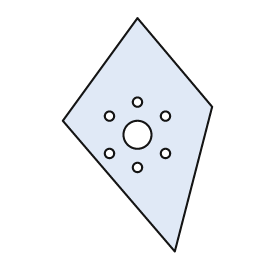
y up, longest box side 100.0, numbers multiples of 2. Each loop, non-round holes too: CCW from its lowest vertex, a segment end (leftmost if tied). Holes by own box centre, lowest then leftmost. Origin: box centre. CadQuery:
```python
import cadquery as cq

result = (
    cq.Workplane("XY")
    .moveTo(16.0, -50.0)
    .lineTo(32.0, 12.0)
    .lineTo(0.0, 50.0)
    .lineTo(-32.0, 6.0)
    .close()
    .moveTo(0.0, -14.0)
    .circle(2.0)
    .moveTo(-12.0, -8.0)
    .circle(2.0)
    .moveTo(12.0, -8.0)
    .circle(2.0)
    .moveTo(0.0, 0.0)
    .circle(6.0)
    .moveTo(-12.0, 8.0)
    .circle(2.0)
    .moveTo(12.0, 8.0)
    .circle(2.0)
    .moveTo(0.0, 14.0)
    .circle(2.0)
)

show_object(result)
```